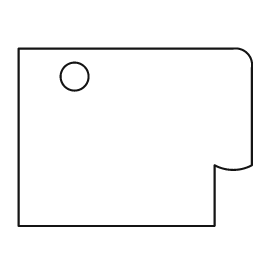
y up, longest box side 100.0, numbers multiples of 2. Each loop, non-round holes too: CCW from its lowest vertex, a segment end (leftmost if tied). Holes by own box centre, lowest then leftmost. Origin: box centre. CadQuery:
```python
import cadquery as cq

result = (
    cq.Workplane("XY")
    .moveTo(-50.0, -38.0)
    .lineTo(34.0, -38.0)
    .lineTo(34.0, -12.0)
    .threePointArc((42.0, -14.0), (50.0, -12.0))
    .lineTo(50.0, 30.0)
    .threePointArc((48.0, 36.0), (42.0, 38.0))
    .lineTo(-50.0, 38.0)
    .close()
    .moveTo(-26.0, 26.0)
    .circle(6.0)
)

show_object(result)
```